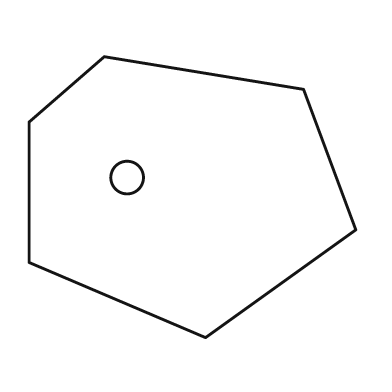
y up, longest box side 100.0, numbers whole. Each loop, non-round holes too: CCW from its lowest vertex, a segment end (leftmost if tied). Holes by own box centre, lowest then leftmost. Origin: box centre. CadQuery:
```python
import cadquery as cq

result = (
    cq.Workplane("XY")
    .moveTo(4.0, -43.0)
    .lineTo(50.0, -10.0)
    .lineTo(34.0, 33.0)
    .lineTo(-27.0, 43.0)
    .lineTo(-50.0, 23.0)
    .lineTo(-50.0, -20.0)
    .close()
    .moveTo(-20.0, 6.0)
    .circle(5.0)
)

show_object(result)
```